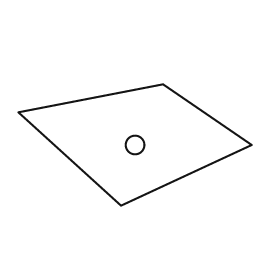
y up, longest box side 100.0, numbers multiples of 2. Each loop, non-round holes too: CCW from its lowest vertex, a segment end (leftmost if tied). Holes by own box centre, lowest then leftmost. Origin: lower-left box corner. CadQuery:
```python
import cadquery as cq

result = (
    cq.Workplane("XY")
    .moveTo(44.0, 0.0)
    .lineTo(100.0, 26.0)
    .lineTo(62.0, 52.0)
    .lineTo(0.0, 40.0)
    .close()
    .moveTo(50.0, 26.0)
    .circle(4.0)
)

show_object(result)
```